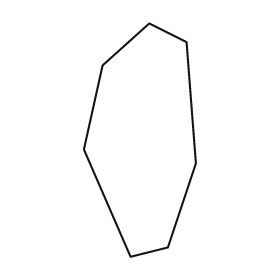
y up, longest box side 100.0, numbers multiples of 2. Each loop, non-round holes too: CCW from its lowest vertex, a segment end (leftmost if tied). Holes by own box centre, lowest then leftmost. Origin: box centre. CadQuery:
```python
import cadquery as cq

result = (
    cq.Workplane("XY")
    .moveTo(-4.0, -50.0)
    .lineTo(12.0, -46.0)
    .lineTo(24.0, -10.0)
    .lineTo(20.0, 42.0)
    .lineTo(4.0, 50.0)
    .lineTo(-16.0, 32.0)
    .lineTo(-24.0, -4.0)
    .close()
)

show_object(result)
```